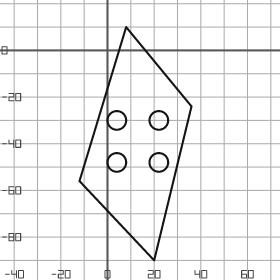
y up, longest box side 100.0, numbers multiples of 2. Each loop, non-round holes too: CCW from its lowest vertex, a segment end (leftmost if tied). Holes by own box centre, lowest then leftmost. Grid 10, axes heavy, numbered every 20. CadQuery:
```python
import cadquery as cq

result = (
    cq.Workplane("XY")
    .moveTo(20.0, -90.0)
    .lineTo(36.0, -24.0)
    .lineTo(8.0, 10.0)
    .lineTo(-12.0, -56.0)
    .close()
    .moveTo(4.0, -48.0)
    .circle(4.0)
    .moveTo(22.0, -48.0)
    .circle(4.0)
    .moveTo(4.0, -30.0)
    .circle(4.0)
    .moveTo(22.0, -30.0)
    .circle(4.0)
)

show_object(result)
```